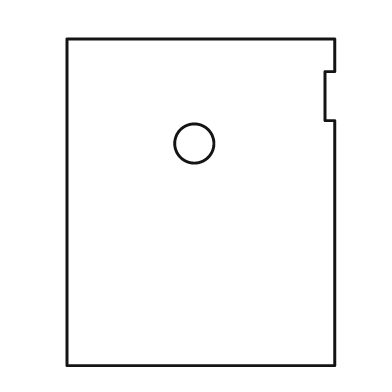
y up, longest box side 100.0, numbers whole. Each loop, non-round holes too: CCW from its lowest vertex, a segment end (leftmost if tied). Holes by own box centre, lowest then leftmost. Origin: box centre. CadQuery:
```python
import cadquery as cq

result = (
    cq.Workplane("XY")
    .moveTo(-41.0, -50.0)
    .lineTo(41.0, -50.0)
    .lineTo(41.0, 25.0)
    .lineTo(38.0, 25.0)
    .lineTo(38.0, 40.0)
    .lineTo(41.0, 40.0)
    .lineTo(41.0, 50.0)
    .lineTo(-41.0, 50.0)
    .close()
    .moveTo(-2.0, 18.0)
    .circle(6.0)
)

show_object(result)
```